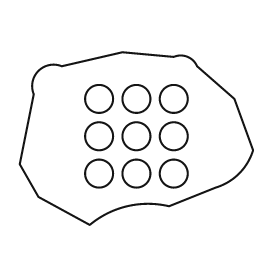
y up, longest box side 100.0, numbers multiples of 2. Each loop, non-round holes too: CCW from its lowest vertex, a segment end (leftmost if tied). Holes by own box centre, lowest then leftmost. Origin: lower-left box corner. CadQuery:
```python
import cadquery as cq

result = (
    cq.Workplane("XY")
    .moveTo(30.0, 0.0)
    .threePointArc((46.0, 8.0), (64.0, 8.0))
    .lineTo(84.0, 16.0)
    .threePointArc((94.0, 22.0), (100.0, 32.0))
    .lineTo(92.0, 54.0)
    .lineTo(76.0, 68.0)
    .threePointArc((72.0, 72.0), (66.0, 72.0))
    .lineTo(44.0, 74.0)
    .lineTo(18.0, 68.0)
    .threePointArc((8.0, 66.0), (6.0, 56.0))
    .lineTo(0.0, 26.0)
    .lineTo(8.0, 12.0)
    .close()
    .moveTo(34.0, 22.0)
    .circle(6.0)
    .moveTo(50.0, 22.0)
    .circle(6.0)
    .moveTo(66.0, 22.0)
    .circle(6.0)
    .moveTo(34.0, 38.0)
    .circle(6.0)
    .moveTo(50.0, 38.0)
    .circle(6.0)
    .moveTo(66.0, 38.0)
    .circle(6.0)
    .moveTo(34.0, 54.0)
    .circle(6.0)
    .moveTo(50.0, 54.0)
    .circle(6.0)
    .moveTo(66.0, 54.0)
    .circle(6.0)
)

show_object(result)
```